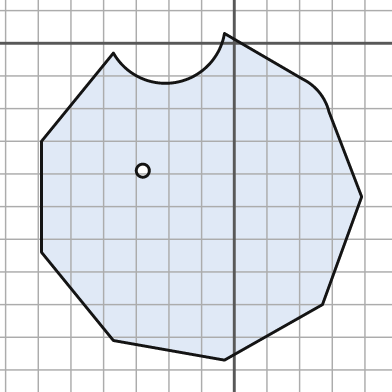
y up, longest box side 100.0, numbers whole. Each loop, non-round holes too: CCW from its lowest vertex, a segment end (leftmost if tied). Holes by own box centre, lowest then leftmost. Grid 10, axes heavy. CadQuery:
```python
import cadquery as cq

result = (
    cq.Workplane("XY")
    .moveTo(-3.0, -97.0)
    .lineTo(27.0, -80.0)
    .lineTo(39.0, -47.0)
    .lineTo(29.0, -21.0)
    .threePointArc((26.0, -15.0), (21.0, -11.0))
    .lineTo(-3.0, 3.0)
    .threePointArc((-18.0, -12.0), (-37.0, -3.0))
    .lineTo(-59.0, -30.0)
    .lineTo(-59.0, -64.0)
    .lineTo(-37.0, -91.0)
    .close()
    .moveTo(-28.0, -39.0)
    .circle(2.0)
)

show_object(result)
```